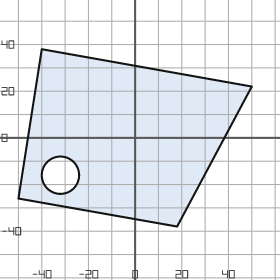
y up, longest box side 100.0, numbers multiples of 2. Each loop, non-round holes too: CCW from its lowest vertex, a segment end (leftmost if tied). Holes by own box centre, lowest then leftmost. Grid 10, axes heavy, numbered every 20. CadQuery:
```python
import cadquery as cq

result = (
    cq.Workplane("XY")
    .moveTo(18.0, -38.0)
    .lineTo(50.0, 22.0)
    .lineTo(-40.0, 38.0)
    .lineTo(-50.0, -26.0)
    .close()
    .moveTo(-32.0, -16.0)
    .circle(8.0)
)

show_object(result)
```